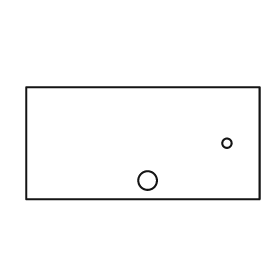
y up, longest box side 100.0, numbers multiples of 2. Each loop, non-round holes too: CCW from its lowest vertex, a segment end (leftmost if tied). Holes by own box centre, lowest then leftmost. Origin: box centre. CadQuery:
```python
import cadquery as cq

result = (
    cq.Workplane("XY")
    .moveTo(-50.0, -24.0)
    .lineTo(50.0, -24.0)
    .lineTo(50.0, 24.0)
    .lineTo(-50.0, 24.0)
    .close()
    .moveTo(2.0, -16.0)
    .circle(4.0)
    .moveTo(36.0, 0.0)
    .circle(2.0)
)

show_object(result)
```